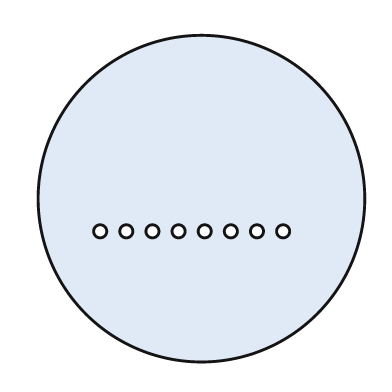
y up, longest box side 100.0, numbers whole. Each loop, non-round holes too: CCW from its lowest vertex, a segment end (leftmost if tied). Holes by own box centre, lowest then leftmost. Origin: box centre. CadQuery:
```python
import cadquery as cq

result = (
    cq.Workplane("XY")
    .moveTo(0.0, 0.0)
    .circle(50.0)
    .moveTo(-31.0, -10.0)
    .circle(2.0)
    .moveTo(-23.0, -10.0)
    .circle(2.0)
    .moveTo(-15.0, -10.0)
    .circle(2.0)
    .moveTo(-7.0, -10.0)
    .circle(2.0)
    .moveTo(1.0, -10.0)
    .circle(2.0)
    .moveTo(9.0, -10.0)
    .circle(2.0)
    .moveTo(17.0, -10.0)
    .circle(2.0)
    .moveTo(25.0, -10.0)
    .circle(2.0)
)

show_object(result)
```